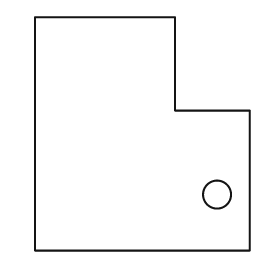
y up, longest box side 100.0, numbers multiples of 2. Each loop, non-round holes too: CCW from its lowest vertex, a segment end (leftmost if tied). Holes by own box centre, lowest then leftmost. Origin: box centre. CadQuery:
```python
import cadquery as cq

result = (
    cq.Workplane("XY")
    .moveTo(-46.0, -50.0)
    .lineTo(46.0, -50.0)
    .lineTo(46.0, 10.0)
    .lineTo(14.0, 10.0)
    .lineTo(14.0, 50.0)
    .lineTo(-46.0, 50.0)
    .close()
    .moveTo(32.0, -26.0)
    .circle(6.0)
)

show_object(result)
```